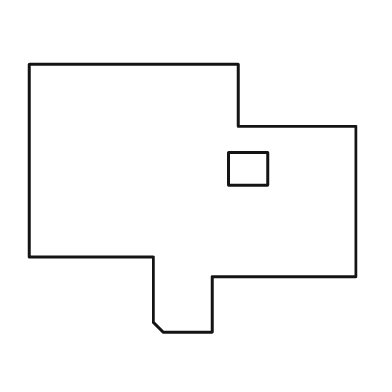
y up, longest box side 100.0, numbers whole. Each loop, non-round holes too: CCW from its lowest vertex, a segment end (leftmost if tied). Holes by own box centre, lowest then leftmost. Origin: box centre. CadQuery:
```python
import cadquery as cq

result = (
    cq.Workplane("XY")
    .moveTo(-9.0, -41.0)
    .lineTo(6.0, -41.0)
    .lineTo(6.0, -24.0)
    .lineTo(50.0, -24.0)
    .lineTo(50.0, 22.0)
    .lineTo(14.0, 22.0)
    .lineTo(14.0, 41.0)
    .lineTo(-50.0, 41.0)
    .lineTo(-50.0, -18.0)
    .lineTo(-12.0, -18.0)
    .lineTo(-12.0, -38.0)
    .close()
    .moveTo(11.0, 4.0)
    .lineTo(23.0, 4.0)
    .lineTo(23.0, 14.0)
    .lineTo(11.0, 14.0)
    .close()
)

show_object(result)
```